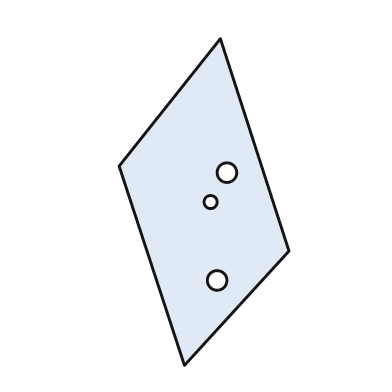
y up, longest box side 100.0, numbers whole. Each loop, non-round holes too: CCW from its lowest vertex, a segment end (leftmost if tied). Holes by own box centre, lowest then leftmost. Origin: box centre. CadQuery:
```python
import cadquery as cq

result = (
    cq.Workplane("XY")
    .moveTo(-6.0, -50.0)
    .lineTo(26.0, -15.0)
    .lineTo(5.0, 50.0)
    .lineTo(-26.0, 11.0)
    .close()
    .moveTo(4.0, -24.0)
    .circle(3.0)
    .moveTo(2.0, 0.0)
    .circle(2.0)
    .moveTo(7.0, 9.0)
    .circle(3.0)
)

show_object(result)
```